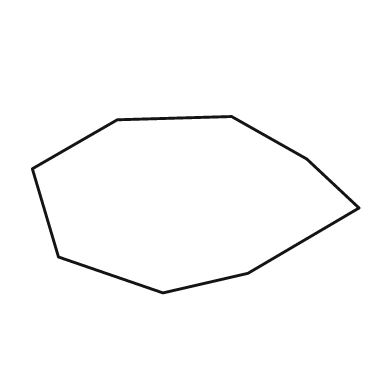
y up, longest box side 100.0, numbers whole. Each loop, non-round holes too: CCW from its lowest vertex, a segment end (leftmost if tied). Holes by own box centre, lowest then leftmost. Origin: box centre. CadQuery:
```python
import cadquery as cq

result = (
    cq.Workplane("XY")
    .moveTo(-10.0, -27.0)
    .lineTo(16.0, -21.0)
    .lineTo(50.0, -1.0)
    .lineTo(34.0, 14.0)
    .lineTo(11.0, 27.0)
    .lineTo(-24.0, 26.0)
    .lineTo(-50.0, 11.0)
    .lineTo(-42.0, -16.0)
    .close()
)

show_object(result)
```